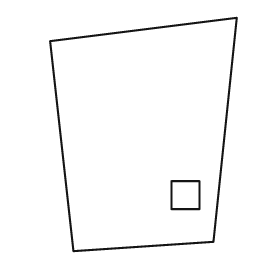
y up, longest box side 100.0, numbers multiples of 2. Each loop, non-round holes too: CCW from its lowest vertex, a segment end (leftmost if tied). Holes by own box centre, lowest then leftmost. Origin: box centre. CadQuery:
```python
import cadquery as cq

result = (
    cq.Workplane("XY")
    .moveTo(-30.0, -50.0)
    .lineTo(30.0, -46.0)
    .lineTo(40.0, 50.0)
    .lineTo(-40.0, 40.0)
    .close()
    .moveTo(12.0, -32.0)
    .lineTo(24.0, -32.0)
    .lineTo(24.0, -20.0)
    .lineTo(12.0, -20.0)
    .close()
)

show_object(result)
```